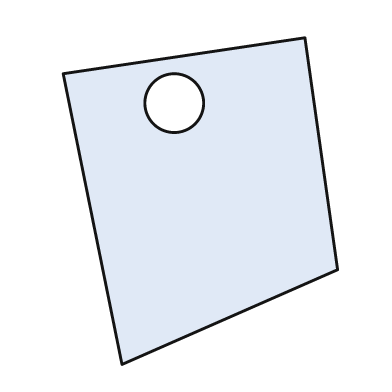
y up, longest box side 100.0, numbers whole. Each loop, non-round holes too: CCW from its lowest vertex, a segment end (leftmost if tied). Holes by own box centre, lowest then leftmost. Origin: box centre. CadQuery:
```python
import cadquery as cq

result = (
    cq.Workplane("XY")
    .moveTo(-24.0, -50.0)
    .lineTo(42.0, -21.0)
    .lineTo(32.0, 50.0)
    .lineTo(-42.0, 39.0)
    .close()
    .moveTo(-8.0, 30.0)
    .circle(9.0)
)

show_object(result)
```